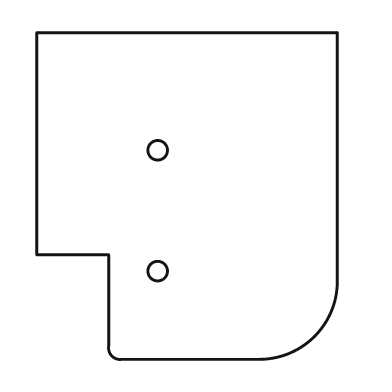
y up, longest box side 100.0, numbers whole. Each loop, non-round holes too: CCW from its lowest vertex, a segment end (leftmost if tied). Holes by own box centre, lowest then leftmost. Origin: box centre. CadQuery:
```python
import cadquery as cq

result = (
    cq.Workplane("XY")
    .moveTo(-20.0, -50.0)
    .lineTo(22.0, -50.0)
    .threePointArc((39.0, -43.0), (46.0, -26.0))
    .lineTo(46.0, 50.0)
    .lineTo(-46.0, 50.0)
    .lineTo(-46.0, -18.0)
    .lineTo(-24.0, -18.0)
    .lineTo(-24.0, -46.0)
    .threePointArc((-23.0, -49.0), (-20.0, -50.0))
    .close()
    .moveTo(-9.0, -23.0)
    .circle(3.0)
    .moveTo(-9.0, 14.0)
    .circle(3.0)
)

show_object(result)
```